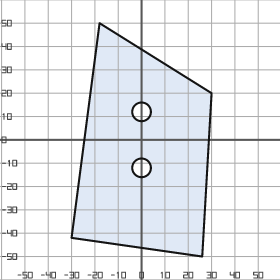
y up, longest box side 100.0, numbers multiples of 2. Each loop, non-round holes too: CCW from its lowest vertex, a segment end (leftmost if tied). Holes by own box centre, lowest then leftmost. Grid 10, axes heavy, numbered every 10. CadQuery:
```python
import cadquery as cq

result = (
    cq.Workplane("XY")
    .moveTo(26.0, -50.0)
    .lineTo(30.0, 20.0)
    .lineTo(-18.0, 50.0)
    .lineTo(-30.0, -42.0)
    .close()
    .moveTo(0.0, -12.0)
    .circle(4.0)
    .moveTo(0.0, 12.0)
    .circle(4.0)
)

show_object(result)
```